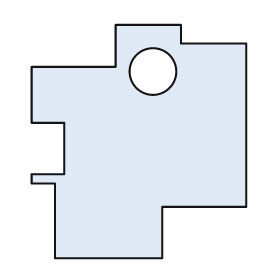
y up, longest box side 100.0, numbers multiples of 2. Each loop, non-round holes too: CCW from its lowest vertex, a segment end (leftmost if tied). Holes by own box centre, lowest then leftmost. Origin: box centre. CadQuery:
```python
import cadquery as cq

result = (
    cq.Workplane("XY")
    .moveTo(-36.0, -50.0)
    .lineTo(10.0, -50.0)
    .lineTo(10.0, -28.0)
    .lineTo(46.0, -28.0)
    .lineTo(46.0, 42.0)
    .lineTo(18.0, 42.0)
    .lineTo(18.0, 50.0)
    .lineTo(-10.0, 50.0)
    .lineTo(-10.0, 32.0)
    .lineTo(-46.0, 32.0)
    .lineTo(-46.0, 8.0)
    .lineTo(-32.0, 8.0)
    .lineTo(-32.0, -14.0)
    .lineTo(-46.0, -14.0)
    .lineTo(-46.0, -18.0)
    .lineTo(-36.0, -18.0)
    .close()
    .moveTo(6.0, 30.0)
    .circle(10.0)
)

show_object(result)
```